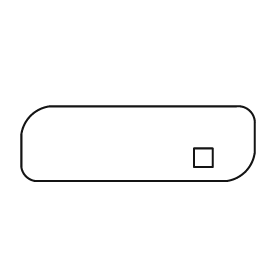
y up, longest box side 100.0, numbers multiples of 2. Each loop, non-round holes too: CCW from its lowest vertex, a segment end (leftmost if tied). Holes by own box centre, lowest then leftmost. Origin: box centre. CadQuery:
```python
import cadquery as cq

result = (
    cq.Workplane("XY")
    .moveTo(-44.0, -16.0)
    .lineTo(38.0, -16.0)
    .threePointArc((46.0, -12.0), (50.0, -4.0))
    .lineTo(50.0, 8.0)
    .threePointArc((48.0, 14.0), (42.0, 16.0))
    .lineTo(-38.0, 16.0)
    .threePointArc((-46.0, 12.0), (-50.0, 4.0))
    .lineTo(-50.0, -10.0)
    .threePointArc((-48.0, -14.0), (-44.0, -16.0))
    .close()
    .moveTo(24.0, -10.0)
    .lineTo(32.0, -10.0)
    .lineTo(32.0, -2.0)
    .lineTo(24.0, -2.0)
    .close()
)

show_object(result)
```